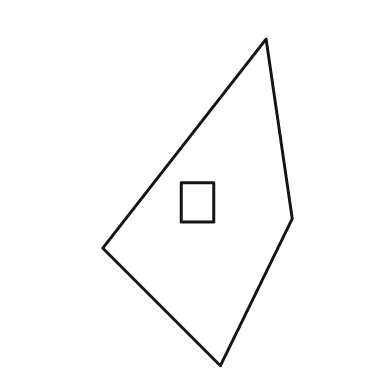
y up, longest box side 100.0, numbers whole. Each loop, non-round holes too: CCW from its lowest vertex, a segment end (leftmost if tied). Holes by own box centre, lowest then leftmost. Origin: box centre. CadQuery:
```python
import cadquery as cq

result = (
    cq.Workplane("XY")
    .moveTo(7.0, -50.0)
    .lineTo(29.0, -5.0)
    .lineTo(21.0, 50.0)
    .lineTo(-29.0, -14.0)
    .close()
    .moveTo(-5.0, -6.0)
    .lineTo(5.0, -6.0)
    .lineTo(5.0, 6.0)
    .lineTo(-5.0, 6.0)
    .close()
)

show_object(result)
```